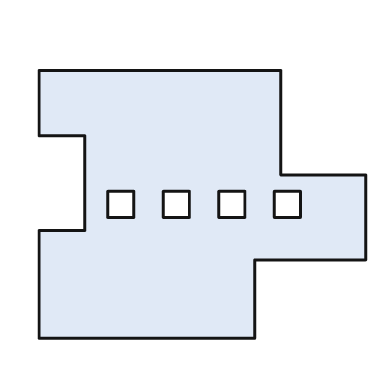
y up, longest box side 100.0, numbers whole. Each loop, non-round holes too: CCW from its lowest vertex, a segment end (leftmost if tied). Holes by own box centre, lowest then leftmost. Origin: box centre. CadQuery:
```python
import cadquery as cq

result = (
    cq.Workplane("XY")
    .moveTo(-50.0, -41.0)
    .lineTo(16.0, -41.0)
    .lineTo(16.0, -17.0)
    .lineTo(50.0, -17.0)
    .lineTo(50.0, 9.0)
    .lineTo(24.0, 9.0)
    .lineTo(24.0, 41.0)
    .lineTo(-50.0, 41.0)
    .lineTo(-50.0, 21.0)
    .lineTo(-36.0, 21.0)
    .lineTo(-36.0, -8.0)
    .lineTo(-50.0, -8.0)
    .close()
    .moveTo(-29.0, -4.0)
    .lineTo(-21.0, -4.0)
    .lineTo(-21.0, 4.0)
    .lineTo(-29.0, 4.0)
    .close()
    .moveTo(-12.0, -4.0)
    .lineTo(-4.0, -4.0)
    .lineTo(-4.0, 4.0)
    .lineTo(-12.0, 4.0)
    .close()
    .moveTo(5.0, -4.0)
    .lineTo(13.0, -4.0)
    .lineTo(13.0, 4.0)
    .lineTo(5.0, 4.0)
    .close()
    .moveTo(22.0, -4.0)
    .lineTo(30.0, -4.0)
    .lineTo(30.0, 4.0)
    .lineTo(22.0, 4.0)
    .close()
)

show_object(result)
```